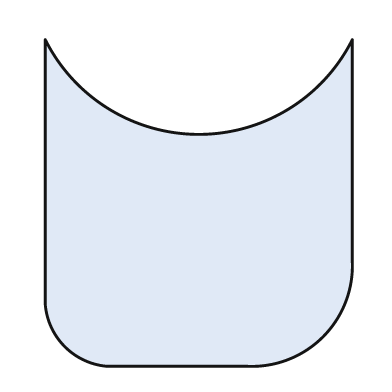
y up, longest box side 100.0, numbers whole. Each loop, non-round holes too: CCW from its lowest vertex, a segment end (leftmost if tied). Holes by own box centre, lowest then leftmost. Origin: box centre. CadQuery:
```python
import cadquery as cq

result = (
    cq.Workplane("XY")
    .moveTo(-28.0, -50.0)
    .lineTo(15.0, -50.0)
    .threePointArc((38.0, -41.0), (47.0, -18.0))
    .lineTo(47.0, 50.0)
    .threePointArc((0.0, 21.0), (-47.0, 50.0))
    .lineTo(-47.0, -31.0)
    .threePointArc((-41.0, -44.0), (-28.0, -50.0))
    .close()
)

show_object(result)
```